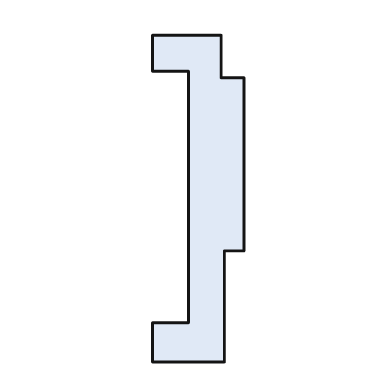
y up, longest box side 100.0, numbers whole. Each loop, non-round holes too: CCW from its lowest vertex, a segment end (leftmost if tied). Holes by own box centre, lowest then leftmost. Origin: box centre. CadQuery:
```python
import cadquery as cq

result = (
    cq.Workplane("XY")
    .moveTo(-14.0, -50.0)
    .lineTo(8.0, -50.0)
    .lineTo(8.0, -16.0)
    .lineTo(14.0, -16.0)
    .lineTo(14.0, 37.0)
    .lineTo(7.0, 37.0)
    .lineTo(7.0, 50.0)
    .lineTo(-14.0, 50.0)
    .lineTo(-14.0, 39.0)
    .lineTo(-3.0, 39.0)
    .lineTo(-3.0, -38.0)
    .lineTo(-14.0, -38.0)
    .close()
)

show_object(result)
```